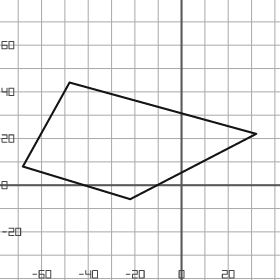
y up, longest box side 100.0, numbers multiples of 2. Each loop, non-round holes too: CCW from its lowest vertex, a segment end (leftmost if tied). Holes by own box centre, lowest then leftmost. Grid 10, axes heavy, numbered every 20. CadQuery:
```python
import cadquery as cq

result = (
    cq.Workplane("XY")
    .moveTo(-22.0, -6.0)
    .lineTo(32.0, 22.0)
    .lineTo(-48.0, 44.0)
    .lineTo(-68.0, 8.0)
    .close()
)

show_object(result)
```